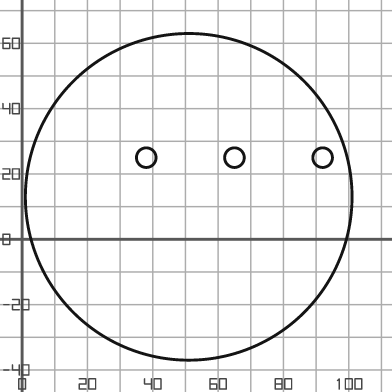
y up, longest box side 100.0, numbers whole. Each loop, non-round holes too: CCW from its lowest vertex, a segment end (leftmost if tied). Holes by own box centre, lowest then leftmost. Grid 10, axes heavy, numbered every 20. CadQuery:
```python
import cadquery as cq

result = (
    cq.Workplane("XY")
    .moveTo(51.0, 13.0)
    .circle(50.0)
    .moveTo(38.0, 25.0)
    .circle(3.0)
    .moveTo(65.0, 25.0)
    .circle(3.0)
    .moveTo(92.0, 25.0)
    .circle(3.0)
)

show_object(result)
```